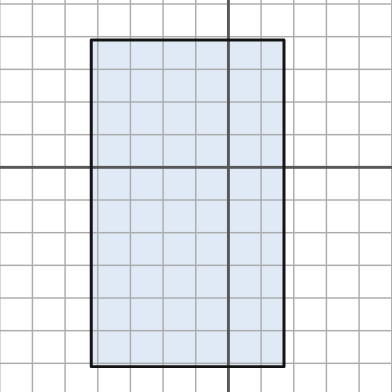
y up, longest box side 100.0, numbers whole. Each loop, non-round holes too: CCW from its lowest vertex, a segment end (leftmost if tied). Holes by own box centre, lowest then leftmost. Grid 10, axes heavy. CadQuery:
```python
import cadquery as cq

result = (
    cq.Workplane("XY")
    .moveTo(-42.0, -61.0)
    .lineTo(17.0, -61.0)
    .lineTo(17.0, 39.0)
    .lineTo(-42.0, 39.0)
    .close()
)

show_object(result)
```